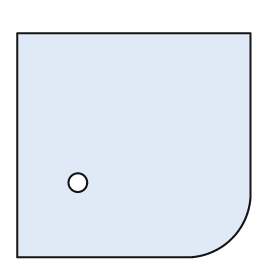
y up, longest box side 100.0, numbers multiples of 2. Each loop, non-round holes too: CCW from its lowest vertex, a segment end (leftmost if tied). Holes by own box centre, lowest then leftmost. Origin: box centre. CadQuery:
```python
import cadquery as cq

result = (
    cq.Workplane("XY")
    .moveTo(-50.0, -48.0)
    .lineTo(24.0, -48.0)
    .threePointArc((42.0, -40.0), (50.0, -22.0))
    .lineTo(50.0, 48.0)
    .lineTo(-50.0, 48.0)
    .close()
    .moveTo(-24.0, -16.0)
    .circle(4.0)
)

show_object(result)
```